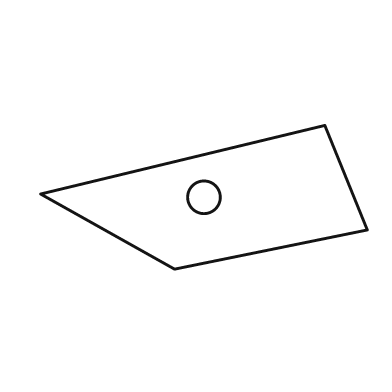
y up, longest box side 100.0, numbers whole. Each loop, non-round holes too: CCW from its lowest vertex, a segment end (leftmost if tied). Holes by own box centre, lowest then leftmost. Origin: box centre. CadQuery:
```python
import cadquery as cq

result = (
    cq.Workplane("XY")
    .moveTo(-9.0, -22.0)
    .lineTo(50.0, -10.0)
    .lineTo(37.0, 22.0)
    .lineTo(-50.0, 1.0)
    .close()
    .moveTo(0.0, 0.0)
    .circle(5.0)
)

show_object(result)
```